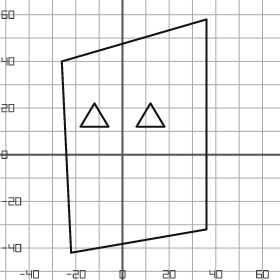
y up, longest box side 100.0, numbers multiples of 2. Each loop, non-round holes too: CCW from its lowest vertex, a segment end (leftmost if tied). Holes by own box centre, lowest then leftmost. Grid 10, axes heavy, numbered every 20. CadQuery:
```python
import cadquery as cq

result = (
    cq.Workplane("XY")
    .moveTo(-22.0, -42.0)
    .lineTo(36.0, -32.0)
    .lineTo(36.0, 58.0)
    .lineTo(-26.0, 40.0)
    .close()
    .moveTo(-18.0, 12.0)
    .lineTo(-6.0, 12.0)
    .lineTo(-12.0, 22.0)
    .close()
    .moveTo(6.0, 12.0)
    .lineTo(18.0, 12.0)
    .lineTo(12.0, 22.0)
    .close()
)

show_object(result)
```